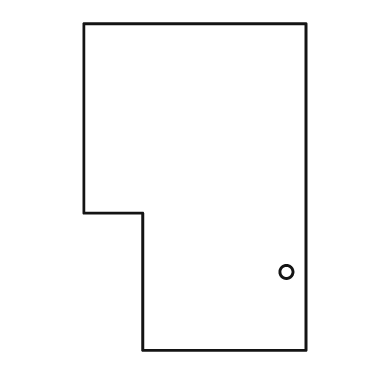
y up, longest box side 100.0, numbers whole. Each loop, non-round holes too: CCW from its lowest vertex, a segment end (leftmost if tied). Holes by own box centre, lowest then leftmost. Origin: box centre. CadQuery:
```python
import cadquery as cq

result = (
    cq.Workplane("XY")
    .moveTo(-16.0, -50.0)
    .lineTo(34.0, -50.0)
    .lineTo(34.0, 50.0)
    .lineTo(-34.0, 50.0)
    .lineTo(-34.0, -8.0)
    .lineTo(-16.0, -8.0)
    .close()
    .moveTo(28.0, -26.0)
    .circle(2.0)
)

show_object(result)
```